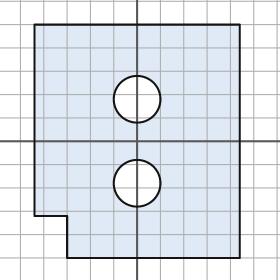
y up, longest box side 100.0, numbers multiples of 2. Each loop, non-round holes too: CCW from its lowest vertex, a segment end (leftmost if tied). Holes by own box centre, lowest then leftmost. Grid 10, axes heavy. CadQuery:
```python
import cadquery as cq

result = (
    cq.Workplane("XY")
    .moveTo(-30.0, -50.0)
    .lineTo(44.0, -50.0)
    .lineTo(44.0, 50.0)
    .lineTo(-44.0, 50.0)
    .lineTo(-44.0, -32.0)
    .lineTo(-30.0, -32.0)
    .close()
    .moveTo(0.0, -18.0)
    .circle(10.0)
    .moveTo(0.0, 18.0)
    .circle(10.0)
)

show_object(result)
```